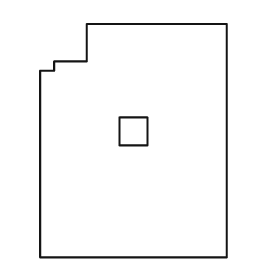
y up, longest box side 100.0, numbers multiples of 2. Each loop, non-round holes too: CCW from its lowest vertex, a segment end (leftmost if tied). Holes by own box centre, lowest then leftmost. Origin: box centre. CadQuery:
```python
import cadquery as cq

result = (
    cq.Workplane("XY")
    .moveTo(-40.0, -50.0)
    .lineTo(40.0, -50.0)
    .lineTo(40.0, 50.0)
    .lineTo(-20.0, 50.0)
    .lineTo(-20.0, 34.0)
    .lineTo(-34.0, 34.0)
    .lineTo(-34.0, 30.0)
    .lineTo(-40.0, 30.0)
    .close()
    .moveTo(-6.0, -2.0)
    .lineTo(6.0, -2.0)
    .lineTo(6.0, 10.0)
    .lineTo(-6.0, 10.0)
    .close()
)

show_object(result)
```